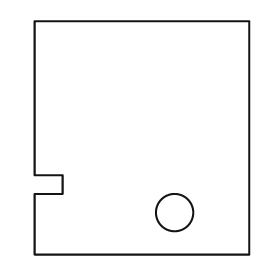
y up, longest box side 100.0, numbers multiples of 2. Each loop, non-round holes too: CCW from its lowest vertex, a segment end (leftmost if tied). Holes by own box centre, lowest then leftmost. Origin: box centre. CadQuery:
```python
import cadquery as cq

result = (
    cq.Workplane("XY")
    .moveTo(-46.0, -50.0)
    .lineTo(46.0, -50.0)
    .lineTo(46.0, 50.0)
    .lineTo(-46.0, 50.0)
    .lineTo(-46.0, -16.0)
    .lineTo(-34.0, -16.0)
    .lineTo(-34.0, -24.0)
    .lineTo(-46.0, -24.0)
    .close()
    .moveTo(14.0, -32.0)
    .circle(8.0)
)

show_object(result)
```